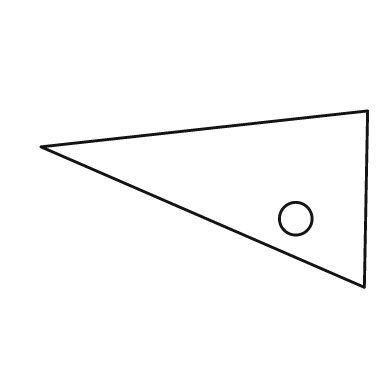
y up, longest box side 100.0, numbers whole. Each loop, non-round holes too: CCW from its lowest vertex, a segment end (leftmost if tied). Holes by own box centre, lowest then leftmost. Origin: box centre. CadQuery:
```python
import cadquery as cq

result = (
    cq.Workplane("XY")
    .moveTo(49.0, -27.0)
    .lineTo(50.0, 27.0)
    .lineTo(-50.0, 16.0)
    .close()
    .moveTo(28.0, -6.0)
    .circle(5.0)
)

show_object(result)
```